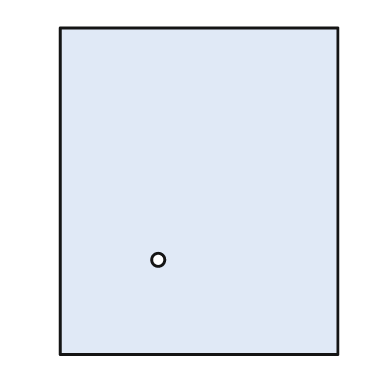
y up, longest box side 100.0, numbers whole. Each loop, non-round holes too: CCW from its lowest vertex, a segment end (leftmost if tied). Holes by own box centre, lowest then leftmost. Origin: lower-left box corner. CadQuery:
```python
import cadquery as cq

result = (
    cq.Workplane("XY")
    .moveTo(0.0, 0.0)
    .lineTo(85.0, 0.0)
    .lineTo(85.0, 100.0)
    .lineTo(0.0, 100.0)
    .close()
    .moveTo(30.0, 29.0)
    .circle(2.0)
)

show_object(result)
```